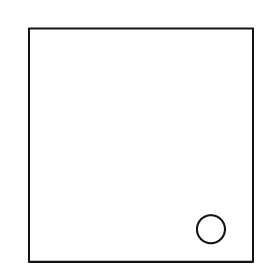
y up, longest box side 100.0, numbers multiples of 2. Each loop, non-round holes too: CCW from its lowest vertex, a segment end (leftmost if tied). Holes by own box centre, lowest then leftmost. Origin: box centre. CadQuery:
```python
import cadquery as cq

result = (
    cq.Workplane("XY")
    .moveTo(-48.0, -50.0)
    .lineTo(48.0, -50.0)
    .lineTo(48.0, 50.0)
    .lineTo(-48.0, 50.0)
    .close()
    .moveTo(30.0, -36.0)
    .circle(6.0)
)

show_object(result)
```